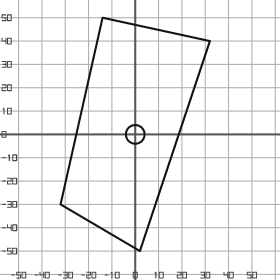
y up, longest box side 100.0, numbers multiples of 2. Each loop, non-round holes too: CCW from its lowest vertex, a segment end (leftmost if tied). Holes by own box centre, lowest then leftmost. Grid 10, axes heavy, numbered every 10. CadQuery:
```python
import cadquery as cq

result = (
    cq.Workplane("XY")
    .moveTo(2.0, -50.0)
    .lineTo(32.0, 40.0)
    .lineTo(-14.0, 50.0)
    .lineTo(-32.0, -30.0)
    .close()
    .moveTo(0.0, 0.0)
    .circle(4.0)
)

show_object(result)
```